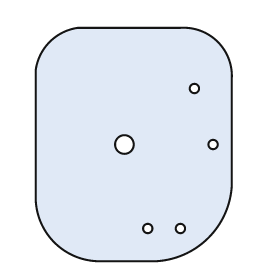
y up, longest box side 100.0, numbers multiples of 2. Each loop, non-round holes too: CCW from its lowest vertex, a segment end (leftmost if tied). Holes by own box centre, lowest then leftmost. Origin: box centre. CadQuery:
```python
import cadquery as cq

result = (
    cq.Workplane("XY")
    .moveTo(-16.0, -50.0)
    .lineTo(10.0, -50.0)
    .threePointArc((32.0, -40.0), (42.0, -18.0))
    .lineTo(42.0, 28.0)
    .threePointArc((36.0, 44.0), (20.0, 50.0))
    .lineTo(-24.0, 50.0)
    .threePointArc((-36.0, 44.0), (-42.0, 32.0))
    .lineTo(-42.0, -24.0)
    .threePointArc((-34.0, -42.0), (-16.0, -50.0))
    .close()
    .moveTo(6.0, -36.0)
    .circle(2.0)
    .moveTo(20.0, -36.0)
    .circle(2.0)
    .moveTo(-4.0, 0.0)
    .circle(4.0)
    .moveTo(34.0, 0.0)
    .circle(2.0)
    .moveTo(26.0, 24.0)
    .circle(2.0)
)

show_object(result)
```